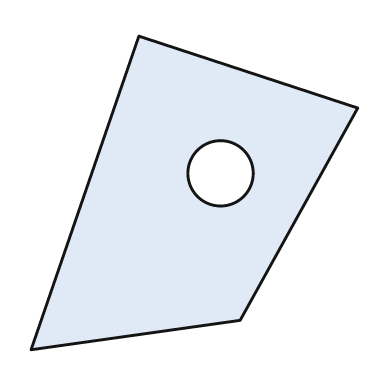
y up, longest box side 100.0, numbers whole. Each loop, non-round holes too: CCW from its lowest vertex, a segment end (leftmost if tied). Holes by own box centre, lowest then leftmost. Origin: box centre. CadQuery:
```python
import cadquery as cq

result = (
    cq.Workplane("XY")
    .moveTo(-50.0, -48.0)
    .lineTo(14.0, -39.0)
    .lineTo(50.0, 26.0)
    .lineTo(-17.0, 48.0)
    .close()
    .moveTo(8.0, 6.0)
    .circle(10.0)
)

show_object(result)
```